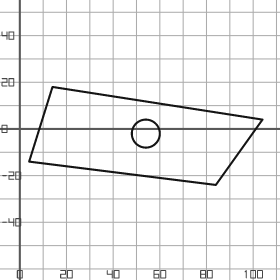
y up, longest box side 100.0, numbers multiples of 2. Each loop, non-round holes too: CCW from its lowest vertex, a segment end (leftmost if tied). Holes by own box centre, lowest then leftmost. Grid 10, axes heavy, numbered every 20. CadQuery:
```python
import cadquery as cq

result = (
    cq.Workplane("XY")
    .moveTo(84.0, -24.0)
    .lineTo(104.0, 4.0)
    .lineTo(14.0, 18.0)
    .lineTo(4.0, -14.0)
    .close()
    .moveTo(54.0, -2.0)
    .circle(6.0)
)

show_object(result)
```